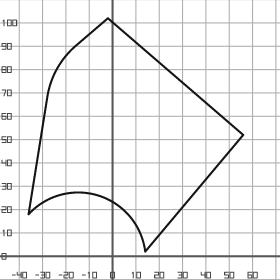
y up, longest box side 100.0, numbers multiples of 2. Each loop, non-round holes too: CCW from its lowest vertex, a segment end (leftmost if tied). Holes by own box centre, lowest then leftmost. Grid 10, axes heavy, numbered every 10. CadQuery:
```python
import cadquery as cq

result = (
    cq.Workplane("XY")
    .moveTo(14.0, 2.0)
    .lineTo(56.0, 52.0)
    .lineTo(-2.0, 102.0)
    .lineTo(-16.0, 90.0)
    .threePointArc((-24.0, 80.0), (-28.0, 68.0))
    .lineTo(-36.0, 18.0)
    .threePointArc((-6.0, 26.0), (14.0, 2.0))
    .close()
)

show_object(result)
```